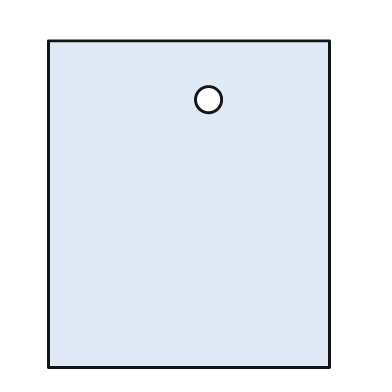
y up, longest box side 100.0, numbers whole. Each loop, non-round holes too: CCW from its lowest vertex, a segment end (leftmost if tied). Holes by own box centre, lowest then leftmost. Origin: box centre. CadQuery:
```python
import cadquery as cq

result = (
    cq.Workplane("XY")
    .moveTo(-43.0, -50.0)
    .lineTo(43.0, -50.0)
    .lineTo(43.0, 50.0)
    .lineTo(-43.0, 50.0)
    .close()
    .moveTo(6.0, 32.0)
    .circle(4.0)
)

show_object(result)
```